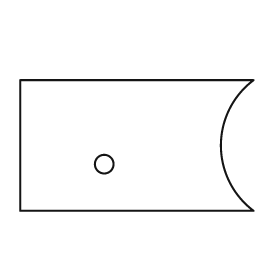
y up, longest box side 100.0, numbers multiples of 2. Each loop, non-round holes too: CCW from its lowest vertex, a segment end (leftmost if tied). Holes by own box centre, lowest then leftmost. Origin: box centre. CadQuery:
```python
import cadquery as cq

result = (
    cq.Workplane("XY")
    .moveTo(-50.0, -28.0)
    .lineTo(50.0, -28.0)
    .threePointArc((36.0, 0.0), (50.0, 28.0))
    .lineTo(-50.0, 28.0)
    .close()
    .moveTo(-14.0, -8.0)
    .circle(4.0)
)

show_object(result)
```